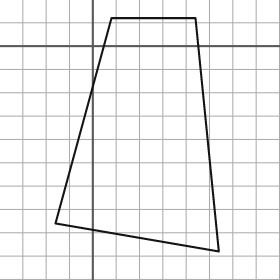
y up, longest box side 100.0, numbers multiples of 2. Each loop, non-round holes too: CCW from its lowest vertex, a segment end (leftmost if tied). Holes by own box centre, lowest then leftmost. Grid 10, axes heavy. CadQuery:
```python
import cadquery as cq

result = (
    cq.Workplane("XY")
    .moveTo(54.0, -88.0)
    .lineTo(44.0, 12.0)
    .lineTo(8.0, 12.0)
    .lineTo(-16.0, -76.0)
    .close()
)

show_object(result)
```